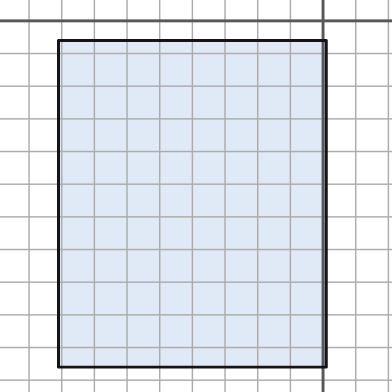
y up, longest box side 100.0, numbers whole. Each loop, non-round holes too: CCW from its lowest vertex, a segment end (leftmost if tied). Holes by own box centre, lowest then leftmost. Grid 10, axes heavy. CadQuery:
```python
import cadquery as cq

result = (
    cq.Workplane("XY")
    .moveTo(-81.0, -106.0)
    .lineTo(1.0, -106.0)
    .lineTo(1.0, -6.0)
    .lineTo(-81.0, -6.0)
    .close()
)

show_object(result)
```